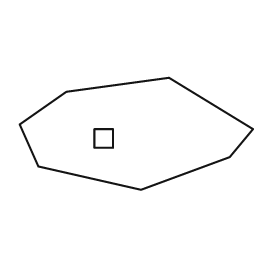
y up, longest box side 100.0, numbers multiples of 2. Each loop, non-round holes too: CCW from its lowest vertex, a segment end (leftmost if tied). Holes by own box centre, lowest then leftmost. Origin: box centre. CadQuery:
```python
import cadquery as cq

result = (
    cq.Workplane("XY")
    .moveTo(2.0, -24.0)
    .lineTo(40.0, -10.0)
    .lineTo(50.0, 2.0)
    .lineTo(14.0, 24.0)
    .lineTo(-30.0, 18.0)
    .lineTo(-50.0, 4.0)
    .lineTo(-42.0, -14.0)
    .close()
    .moveTo(-18.0, -6.0)
    .lineTo(-10.0, -6.0)
    .lineTo(-10.0, 2.0)
    .lineTo(-18.0, 2.0)
    .close()
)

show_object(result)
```